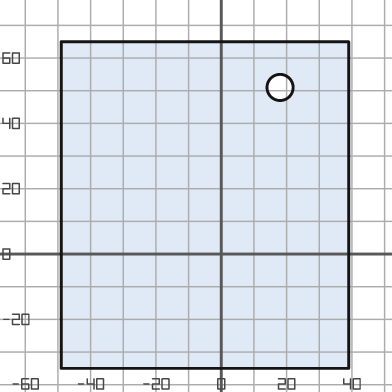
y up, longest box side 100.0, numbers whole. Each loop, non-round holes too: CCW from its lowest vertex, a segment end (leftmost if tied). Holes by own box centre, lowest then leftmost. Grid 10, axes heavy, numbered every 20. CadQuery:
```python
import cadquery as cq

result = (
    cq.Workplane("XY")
    .moveTo(-49.0, -35.0)
    .lineTo(39.0, -35.0)
    .lineTo(39.0, 65.0)
    .lineTo(-49.0, 65.0)
    .close()
    .moveTo(18.0, 51.0)
    .circle(4.0)
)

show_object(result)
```